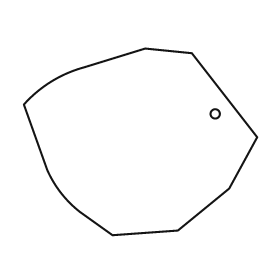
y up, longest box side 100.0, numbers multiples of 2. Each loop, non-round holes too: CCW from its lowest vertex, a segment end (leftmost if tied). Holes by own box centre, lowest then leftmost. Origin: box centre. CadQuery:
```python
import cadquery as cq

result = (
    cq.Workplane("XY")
    .moveTo(-12.0, -40.0)
    .lineTo(16.0, -38.0)
    .lineTo(38.0, -20.0)
    .lineTo(50.0, 2.0)
    .lineTo(22.0, 38.0)
    .lineTo(2.0, 40.0)
    .lineTo(-24.0, 32.0)
    .threePointArc((-38.0, 26.0), (-50.0, 16.0))
    .lineTo(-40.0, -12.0)
    .threePointArc((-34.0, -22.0), (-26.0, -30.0))
    .close()
    .moveTo(32.0, 12.0)
    .circle(2.0)
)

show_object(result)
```